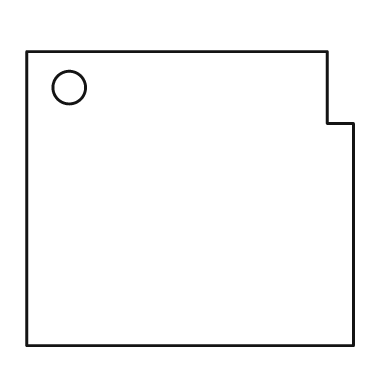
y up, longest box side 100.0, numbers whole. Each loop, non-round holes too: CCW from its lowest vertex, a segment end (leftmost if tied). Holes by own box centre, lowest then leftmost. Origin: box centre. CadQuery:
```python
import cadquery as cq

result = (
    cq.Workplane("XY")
    .moveTo(-50.0, -45.0)
    .lineTo(50.0, -45.0)
    .lineTo(50.0, 23.0)
    .lineTo(42.0, 23.0)
    .lineTo(42.0, 45.0)
    .lineTo(-50.0, 45.0)
    .close()
    .moveTo(-37.0, 34.0)
    .circle(5.0)
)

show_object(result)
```